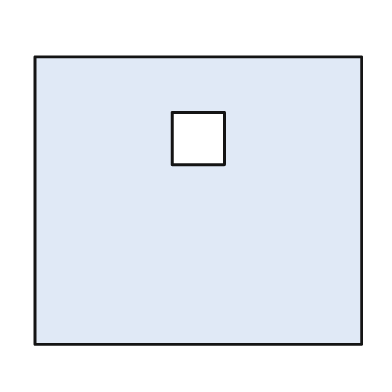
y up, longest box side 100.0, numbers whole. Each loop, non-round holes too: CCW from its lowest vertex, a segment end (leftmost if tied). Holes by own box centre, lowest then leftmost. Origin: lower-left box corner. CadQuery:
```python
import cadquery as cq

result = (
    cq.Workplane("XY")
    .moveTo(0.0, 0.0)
    .lineTo(100.0, 0.0)
    .lineTo(100.0, 88.0)
    .lineTo(0.0, 88.0)
    .close()
    .moveTo(42.0, 55.0)
    .lineTo(58.0, 55.0)
    .lineTo(58.0, 71.0)
    .lineTo(42.0, 71.0)
    .close()
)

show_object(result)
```